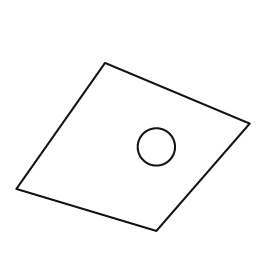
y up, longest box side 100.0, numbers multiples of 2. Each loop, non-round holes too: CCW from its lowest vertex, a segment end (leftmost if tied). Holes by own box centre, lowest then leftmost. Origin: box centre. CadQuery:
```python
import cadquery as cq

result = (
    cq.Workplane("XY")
    .moveTo(10.0, -36.0)
    .lineTo(50.0, 10.0)
    .lineTo(-12.0, 36.0)
    .lineTo(-50.0, -18.0)
    .close()
    .moveTo(10.0, 0.0)
    .circle(8.0)
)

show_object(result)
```